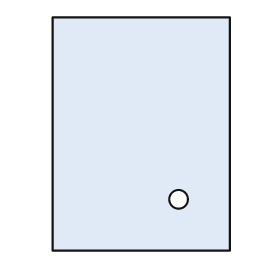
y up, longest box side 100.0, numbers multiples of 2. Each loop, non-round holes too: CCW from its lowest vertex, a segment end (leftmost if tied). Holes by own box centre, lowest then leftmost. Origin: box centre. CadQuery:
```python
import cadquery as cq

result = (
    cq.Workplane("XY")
    .moveTo(-38.0, -50.0)
    .lineTo(38.0, -50.0)
    .lineTo(38.0, 50.0)
    .lineTo(-38.0, 50.0)
    .close()
    .moveTo(16.0, -28.0)
    .circle(4.0)
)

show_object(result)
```